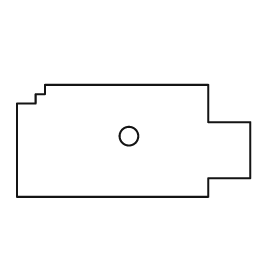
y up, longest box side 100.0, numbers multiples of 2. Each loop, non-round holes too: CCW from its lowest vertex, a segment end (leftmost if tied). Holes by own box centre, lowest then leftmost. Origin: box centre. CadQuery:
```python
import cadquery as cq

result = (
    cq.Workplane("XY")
    .moveTo(-50.0, -24.0)
    .lineTo(32.0, -24.0)
    .lineTo(32.0, -16.0)
    .lineTo(50.0, -16.0)
    .lineTo(50.0, 8.0)
    .lineTo(32.0, 8.0)
    .lineTo(32.0, 24.0)
    .lineTo(-38.0, 24.0)
    .lineTo(-38.0, 20.0)
    .lineTo(-42.0, 20.0)
    .lineTo(-42.0, 16.0)
    .lineTo(-50.0, 16.0)
    .close()
    .moveTo(-2.0, 2.0)
    .circle(4.0)
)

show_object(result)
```